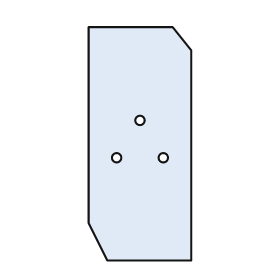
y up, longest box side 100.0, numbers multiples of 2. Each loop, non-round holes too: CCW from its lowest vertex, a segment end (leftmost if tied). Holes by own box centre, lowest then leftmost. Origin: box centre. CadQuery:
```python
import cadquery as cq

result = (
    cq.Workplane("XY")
    .moveTo(-14.0, -50.0)
    .lineTo(22.0, -50.0)
    .lineTo(22.0, 40.0)
    .lineTo(14.0, 50.0)
    .lineTo(-22.0, 50.0)
    .lineTo(-22.0, -34.0)
    .close()
    .moveTo(-10.0, -6.0)
    .circle(2.0)
    .moveTo(10.0, -6.0)
    .circle(2.0)
    .moveTo(0.0, 10.0)
    .circle(2.0)
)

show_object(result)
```